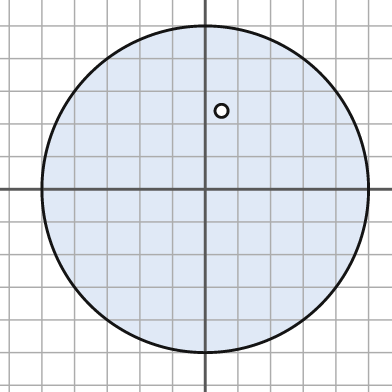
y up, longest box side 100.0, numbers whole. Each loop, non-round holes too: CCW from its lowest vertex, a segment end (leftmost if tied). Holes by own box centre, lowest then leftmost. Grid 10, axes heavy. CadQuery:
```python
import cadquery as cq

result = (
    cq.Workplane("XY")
    .moveTo(0.0, 0.0)
    .circle(50.0)
    .moveTo(5.0, 24.0)
    .circle(2.0)
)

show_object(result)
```